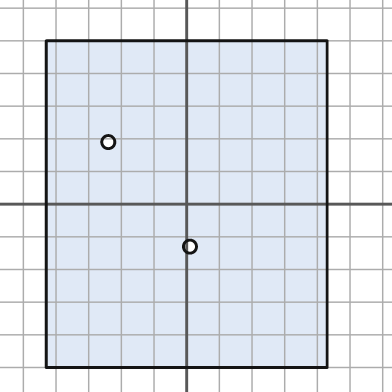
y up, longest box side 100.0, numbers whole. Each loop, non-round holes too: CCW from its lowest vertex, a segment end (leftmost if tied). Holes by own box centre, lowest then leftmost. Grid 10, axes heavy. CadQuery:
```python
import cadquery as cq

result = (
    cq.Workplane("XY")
    .moveTo(-43.0, -50.0)
    .lineTo(43.0, -50.0)
    .lineTo(43.0, 50.0)
    .lineTo(-43.0, 50.0)
    .close()
    .moveTo(1.0, -13.0)
    .circle(2.0)
    .moveTo(-24.0, 19.0)
    .circle(2.0)
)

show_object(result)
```